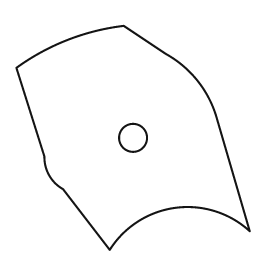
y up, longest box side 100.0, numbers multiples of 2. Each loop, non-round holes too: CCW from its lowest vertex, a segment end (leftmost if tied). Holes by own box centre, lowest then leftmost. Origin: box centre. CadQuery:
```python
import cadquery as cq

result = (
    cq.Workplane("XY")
    .moveTo(-10.0, -48.0)
    .threePointArc((18.0, -30.0), (50.0, -40.0))
    .lineTo(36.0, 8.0)
    .threePointArc((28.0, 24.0), (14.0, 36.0))
    .lineTo(-4.0, 48.0)
    .threePointArc((-28.0, 42.0), (-50.0, 30.0))
    .lineTo(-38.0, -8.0)
    .threePointArc((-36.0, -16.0), (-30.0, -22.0))
    .close()
    .moveTo(0.0, 0.0)
    .circle(6.0)
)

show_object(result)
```